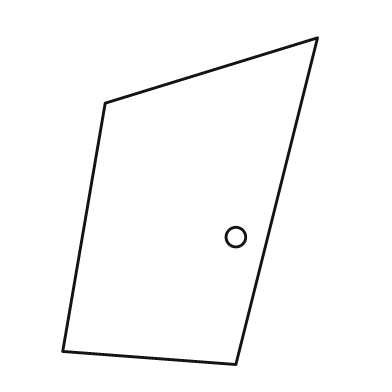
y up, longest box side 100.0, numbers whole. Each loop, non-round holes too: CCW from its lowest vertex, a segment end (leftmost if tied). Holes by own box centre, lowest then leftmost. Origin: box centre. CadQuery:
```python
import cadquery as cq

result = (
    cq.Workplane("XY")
    .moveTo(14.0, -50.0)
    .lineTo(39.0, 50.0)
    .lineTo(-26.0, 30.0)
    .lineTo(-39.0, -46.0)
    .close()
    .moveTo(14.0, -11.0)
    .circle(3.0)
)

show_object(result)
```